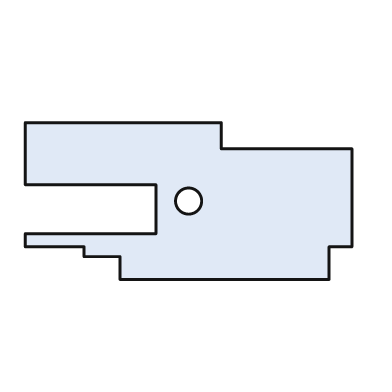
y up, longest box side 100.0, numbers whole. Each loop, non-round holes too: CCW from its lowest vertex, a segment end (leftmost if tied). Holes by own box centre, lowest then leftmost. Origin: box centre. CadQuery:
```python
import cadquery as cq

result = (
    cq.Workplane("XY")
    .moveTo(-21.0, -24.0)
    .lineTo(43.0, -24.0)
    .lineTo(43.0, -14.0)
    .lineTo(50.0, -14.0)
    .lineTo(50.0, 16.0)
    .lineTo(10.0, 16.0)
    .lineTo(10.0, 24.0)
    .lineTo(-50.0, 24.0)
    .lineTo(-50.0, 5.0)
    .lineTo(-10.0, 5.0)
    .lineTo(-10.0, -10.0)
    .lineTo(-50.0, -10.0)
    .lineTo(-50.0, -14.0)
    .lineTo(-32.0, -14.0)
    .lineTo(-32.0, -17.0)
    .lineTo(-21.0, -17.0)
    .close()
    .moveTo(0.0, 0.0)
    .circle(4.0)
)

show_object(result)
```